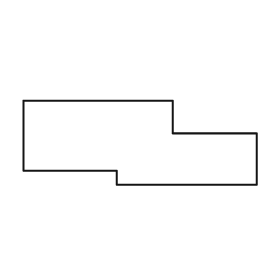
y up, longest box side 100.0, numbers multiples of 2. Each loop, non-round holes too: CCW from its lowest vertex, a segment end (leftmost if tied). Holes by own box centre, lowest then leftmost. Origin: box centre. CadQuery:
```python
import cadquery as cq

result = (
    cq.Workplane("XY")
    .moveTo(-10.0, -18.0)
    .lineTo(50.0, -18.0)
    .lineTo(50.0, 4.0)
    .lineTo(14.0, 4.0)
    .lineTo(14.0, 18.0)
    .lineTo(-50.0, 18.0)
    .lineTo(-50.0, -12.0)
    .lineTo(-10.0, -12.0)
    .close()
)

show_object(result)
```